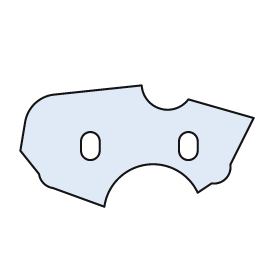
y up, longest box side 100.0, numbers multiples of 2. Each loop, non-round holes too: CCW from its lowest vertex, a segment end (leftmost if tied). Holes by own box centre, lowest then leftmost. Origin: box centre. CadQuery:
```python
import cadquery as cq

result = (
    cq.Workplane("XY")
    .moveTo(-14.0, -26.0)
    .threePointArc((4.0, -8.0), (26.0, -20.0))
    .lineTo(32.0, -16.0)
    .threePointArc((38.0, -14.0), (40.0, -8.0))
    .lineTo(50.0, 12.0)
    .lineTo(22.0, 20.0)
    .threePointArc((10.0, 16.0), (2.0, 26.0))
    .lineTo(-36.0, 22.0)
    .threePointArc((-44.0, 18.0), (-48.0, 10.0))
    .lineTo(-50.0, -2.0)
    .lineTo(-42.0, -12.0)
    .threePointArc((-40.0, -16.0), (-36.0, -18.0))
    .close()
    .moveTo(-24.0, -2.0)
    .threePointArc((-20.0, -6.0), (-16.0, -2.0))
    .lineTo(-16.0, 2.0)
    .threePointArc((-20.0, 6.0), (-24.0, 2.0))
    .close()
    .moveTo(18.0, -2.0)
    .threePointArc((22.0, -6.0), (26.0, -2.0))
    .lineTo(26.0, 2.0)
    .threePointArc((22.0, 6.0), (18.0, 2.0))
    .close()
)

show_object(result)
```